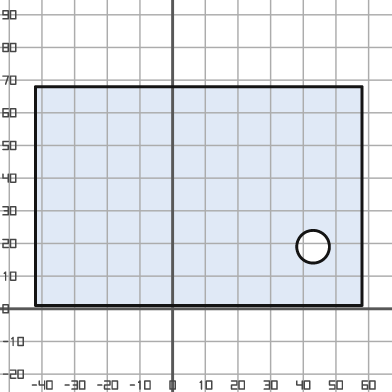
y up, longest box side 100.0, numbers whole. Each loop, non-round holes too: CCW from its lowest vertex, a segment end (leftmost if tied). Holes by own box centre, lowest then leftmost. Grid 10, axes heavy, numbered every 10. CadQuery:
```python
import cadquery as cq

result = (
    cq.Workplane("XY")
    .moveTo(-42.0, 1.0)
    .lineTo(58.0, 1.0)
    .lineTo(58.0, 68.0)
    .lineTo(-42.0, 68.0)
    .close()
    .moveTo(43.0, 19.0)
    .circle(5.0)
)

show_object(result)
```